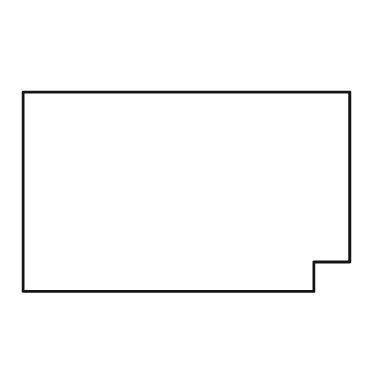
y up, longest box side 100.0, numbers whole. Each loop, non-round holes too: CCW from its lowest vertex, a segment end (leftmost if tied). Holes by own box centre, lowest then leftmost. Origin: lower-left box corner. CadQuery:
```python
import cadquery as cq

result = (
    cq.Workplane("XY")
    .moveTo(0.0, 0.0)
    .lineTo(89.0, 0.0)
    .lineTo(89.0, 9.0)
    .lineTo(100.0, 9.0)
    .lineTo(100.0, 61.0)
    .lineTo(0.0, 61.0)
    .close()
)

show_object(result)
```